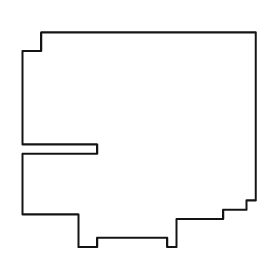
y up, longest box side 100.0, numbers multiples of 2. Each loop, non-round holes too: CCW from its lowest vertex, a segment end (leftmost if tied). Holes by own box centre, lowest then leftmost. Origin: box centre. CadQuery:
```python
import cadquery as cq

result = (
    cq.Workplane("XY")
    .moveTo(-26.0, -46.0)
    .lineTo(-18.0, -46.0)
    .lineTo(-18.0, -42.0)
    .lineTo(12.0, -42.0)
    .lineTo(12.0, -46.0)
    .lineTo(16.0, -46.0)
    .lineTo(16.0, -34.0)
    .lineTo(36.0, -34.0)
    .lineTo(36.0, -30.0)
    .lineTo(46.0, -30.0)
    .lineTo(46.0, -26.0)
    .lineTo(50.0, -26.0)
    .lineTo(50.0, 46.0)
    .lineTo(-42.0, 46.0)
    .lineTo(-42.0, 38.0)
    .lineTo(-50.0, 38.0)
    .lineTo(-50.0, -2.0)
    .lineTo(-18.0, -2.0)
    .lineTo(-18.0, -6.0)
    .lineTo(-50.0, -6.0)
    .lineTo(-50.0, -32.0)
    .lineTo(-26.0, -32.0)
    .close()
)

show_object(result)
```